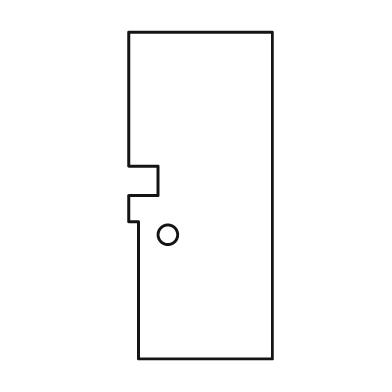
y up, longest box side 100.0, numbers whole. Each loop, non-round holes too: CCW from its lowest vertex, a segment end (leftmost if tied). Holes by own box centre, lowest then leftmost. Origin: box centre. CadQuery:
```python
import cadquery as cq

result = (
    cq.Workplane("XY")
    .moveTo(-19.0, -50.0)
    .lineTo(22.0, -50.0)
    .lineTo(22.0, 50.0)
    .lineTo(-22.0, 50.0)
    .lineTo(-22.0, 9.0)
    .lineTo(-13.0, 9.0)
    .lineTo(-13.0, 0.0)
    .lineTo(-22.0, 0.0)
    .lineTo(-22.0, -8.0)
    .lineTo(-19.0, -8.0)
    .close()
    .moveTo(-10.0, -12.0)
    .circle(3.0)
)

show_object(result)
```